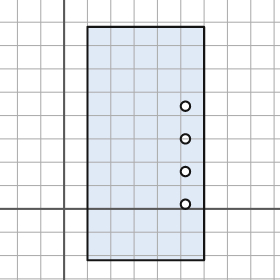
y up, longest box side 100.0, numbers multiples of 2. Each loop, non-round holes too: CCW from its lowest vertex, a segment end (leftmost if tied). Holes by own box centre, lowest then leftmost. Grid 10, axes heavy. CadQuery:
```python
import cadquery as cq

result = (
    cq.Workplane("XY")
    .moveTo(10.0, -22.0)
    .lineTo(60.0, -22.0)
    .lineTo(60.0, 78.0)
    .lineTo(10.0, 78.0)
    .close()
    .moveTo(52.0, 2.0)
    .circle(2.0)
    .moveTo(52.0, 16.0)
    .circle(2.0)
    .moveTo(52.0, 30.0)
    .circle(2.0)
    .moveTo(52.0, 44.0)
    .circle(2.0)
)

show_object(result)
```